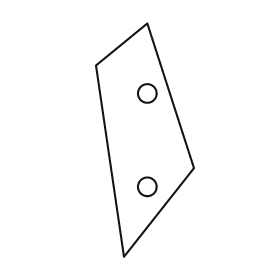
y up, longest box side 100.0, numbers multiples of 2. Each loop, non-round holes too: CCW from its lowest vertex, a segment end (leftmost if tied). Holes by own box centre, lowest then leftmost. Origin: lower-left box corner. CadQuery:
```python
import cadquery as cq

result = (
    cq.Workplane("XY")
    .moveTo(12.0, 0.0)
    .lineTo(42.0, 38.0)
    .lineTo(22.0, 100.0)
    .lineTo(0.0, 82.0)
    .close()
    .moveTo(22.0, 30.0)
    .circle(4.0)
    .moveTo(22.0, 70.0)
    .circle(4.0)
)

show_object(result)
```